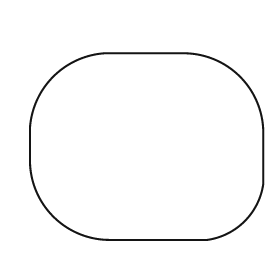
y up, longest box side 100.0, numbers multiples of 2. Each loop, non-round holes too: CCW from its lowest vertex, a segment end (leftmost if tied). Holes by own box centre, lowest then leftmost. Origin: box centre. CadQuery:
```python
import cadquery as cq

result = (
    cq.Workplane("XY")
    .moveTo(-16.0, -40.0)
    .lineTo(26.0, -40.0)
    .threePointArc((42.0, -32.0), (50.0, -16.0))
    .lineTo(50.0, 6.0)
    .threePointArc((40.0, 30.0), (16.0, 40.0))
    .lineTo(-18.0, 40.0)
    .threePointArc((-40.0, 30.0), (-50.0, 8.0))
    .lineTo(-50.0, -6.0)
    .threePointArc((-40.0, -30.0), (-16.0, -40.0))
    .close()
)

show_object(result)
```